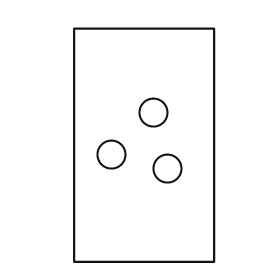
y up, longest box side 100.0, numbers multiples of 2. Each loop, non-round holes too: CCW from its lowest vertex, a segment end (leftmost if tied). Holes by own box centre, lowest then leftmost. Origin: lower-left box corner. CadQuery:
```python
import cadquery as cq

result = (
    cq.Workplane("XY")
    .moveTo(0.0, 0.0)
    .lineTo(60.0, 0.0)
    .lineTo(60.0, 100.0)
    .lineTo(0.0, 100.0)
    .close()
    .moveTo(40.0, 40.0)
    .circle(6.0)
    .moveTo(16.0, 46.0)
    .circle(6.0)
    .moveTo(34.0, 64.0)
    .circle(6.0)
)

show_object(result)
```